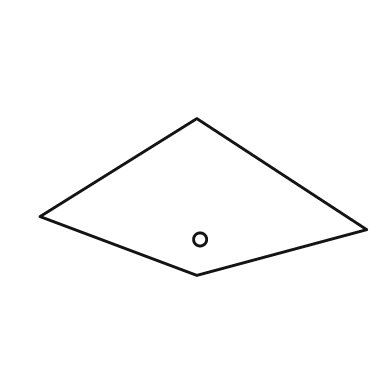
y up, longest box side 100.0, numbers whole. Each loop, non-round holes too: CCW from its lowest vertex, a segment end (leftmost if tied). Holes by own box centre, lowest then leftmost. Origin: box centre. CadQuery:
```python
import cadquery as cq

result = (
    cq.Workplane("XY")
    .moveTo(-2.0, -24.0)
    .lineTo(50.0, -10.0)
    .lineTo(-2.0, 24.0)
    .lineTo(-50.0, -6.0)
    .close()
    .moveTo(-1.0, -13.0)
    .circle(2.0)
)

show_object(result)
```